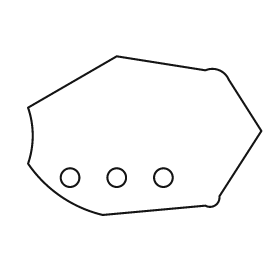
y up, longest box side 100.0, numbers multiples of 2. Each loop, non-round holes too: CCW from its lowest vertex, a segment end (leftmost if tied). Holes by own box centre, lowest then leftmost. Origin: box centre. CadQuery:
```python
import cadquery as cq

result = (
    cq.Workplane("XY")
    .moveTo(-18.0, -34.0)
    .lineTo(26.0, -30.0)
    .threePointArc((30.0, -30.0), (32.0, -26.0))
    .lineTo(50.0, 2.0)
    .lineTo(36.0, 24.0)
    .threePointArc((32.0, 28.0), (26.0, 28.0))
    .lineTo(-12.0, 34.0)
    .lineTo(-50.0, 12.0)
    .threePointArc((-48.0, 0.0), (-50.0, -12.0))
    .threePointArc((-36.0, -26.0), (-18.0, -34.0))
    .close()
    .moveTo(-32.0, -18.0)
    .circle(4.0)
    .moveTo(-12.0, -18.0)
    .circle(4.0)
    .moveTo(8.0, -18.0)
    .circle(4.0)
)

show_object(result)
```